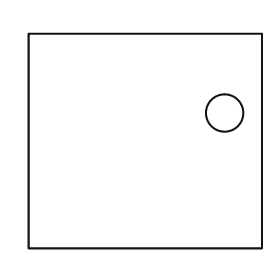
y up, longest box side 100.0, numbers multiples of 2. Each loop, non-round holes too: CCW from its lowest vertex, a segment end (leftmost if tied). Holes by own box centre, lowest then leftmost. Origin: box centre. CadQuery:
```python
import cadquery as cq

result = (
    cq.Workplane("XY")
    .moveTo(-50.0, -46.0)
    .lineTo(50.0, -46.0)
    .lineTo(50.0, 46.0)
    .lineTo(-50.0, 46.0)
    .close()
    .moveTo(34.0, 12.0)
    .circle(8.0)
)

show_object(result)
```